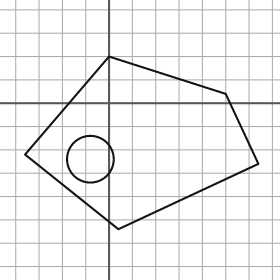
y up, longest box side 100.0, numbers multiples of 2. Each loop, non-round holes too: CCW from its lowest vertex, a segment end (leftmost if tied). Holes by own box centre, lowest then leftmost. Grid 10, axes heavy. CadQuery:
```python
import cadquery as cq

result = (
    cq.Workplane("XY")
    .moveTo(4.0, -54.0)
    .lineTo(64.0, -26.0)
    .lineTo(50.0, 4.0)
    .lineTo(0.0, 20.0)
    .lineTo(-36.0, -22.0)
    .close()
    .moveTo(-8.0, -24.0)
    .circle(10.0)
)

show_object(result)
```